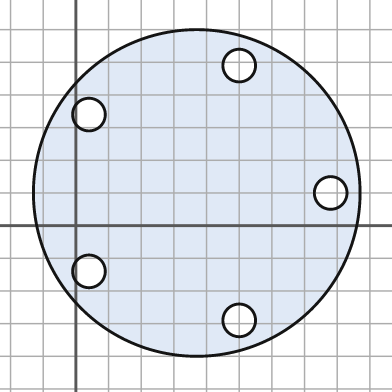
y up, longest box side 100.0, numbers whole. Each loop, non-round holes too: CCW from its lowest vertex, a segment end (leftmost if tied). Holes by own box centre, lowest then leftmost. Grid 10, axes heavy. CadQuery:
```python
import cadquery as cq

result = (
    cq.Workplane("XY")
    .moveTo(37.0, 10.0)
    .circle(50.0)
    .moveTo(50.0, -29.0)
    .circle(5.0)
    .moveTo(4.0, -14.0)
    .circle(5.0)
    .moveTo(78.0, 10.0)
    .circle(5.0)
    .moveTo(4.0, 34.0)
    .circle(5.0)
    .moveTo(50.0, 49.0)
    .circle(5.0)
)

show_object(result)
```